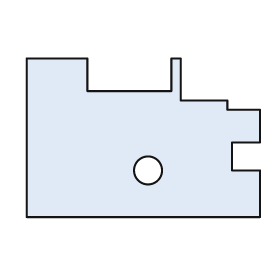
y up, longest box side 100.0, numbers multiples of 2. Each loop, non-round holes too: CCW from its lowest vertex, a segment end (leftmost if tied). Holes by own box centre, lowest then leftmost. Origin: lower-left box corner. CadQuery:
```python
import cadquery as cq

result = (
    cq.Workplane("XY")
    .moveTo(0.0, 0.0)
    .lineTo(100.0, 0.0)
    .lineTo(100.0, 20.0)
    .lineTo(88.0, 20.0)
    .lineTo(88.0, 32.0)
    .lineTo(100.0, 32.0)
    .lineTo(100.0, 46.0)
    .lineTo(86.0, 46.0)
    .lineTo(86.0, 50.0)
    .lineTo(66.0, 50.0)
    .lineTo(66.0, 68.0)
    .lineTo(62.0, 68.0)
    .lineTo(62.0, 54.0)
    .lineTo(26.0, 54.0)
    .lineTo(26.0, 68.0)
    .lineTo(0.0, 68.0)
    .close()
    .moveTo(52.0, 20.0)
    .circle(6.0)
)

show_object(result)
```